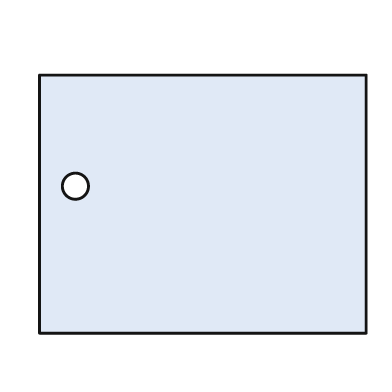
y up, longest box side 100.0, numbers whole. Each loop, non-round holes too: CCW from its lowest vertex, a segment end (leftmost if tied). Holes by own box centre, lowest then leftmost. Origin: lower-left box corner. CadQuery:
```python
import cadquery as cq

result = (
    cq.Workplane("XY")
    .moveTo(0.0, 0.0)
    .lineTo(100.0, 0.0)
    .lineTo(100.0, 79.0)
    .lineTo(0.0, 79.0)
    .close()
    .moveTo(11.0, 45.0)
    .circle(4.0)
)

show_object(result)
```